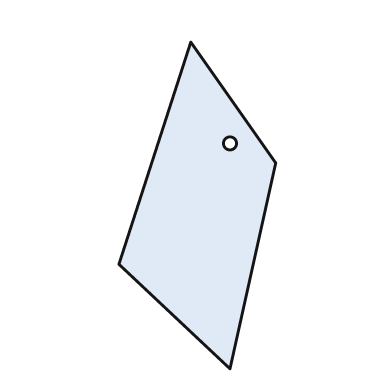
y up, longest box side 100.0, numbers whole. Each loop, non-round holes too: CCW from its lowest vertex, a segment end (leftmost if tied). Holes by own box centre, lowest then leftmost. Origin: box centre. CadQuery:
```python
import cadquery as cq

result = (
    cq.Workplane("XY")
    .moveTo(10.0, -50.0)
    .lineTo(24.0, 13.0)
    .lineTo(-2.0, 50.0)
    .lineTo(-24.0, -18.0)
    .close()
    .moveTo(10.0, 19.0)
    .circle(2.0)
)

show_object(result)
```